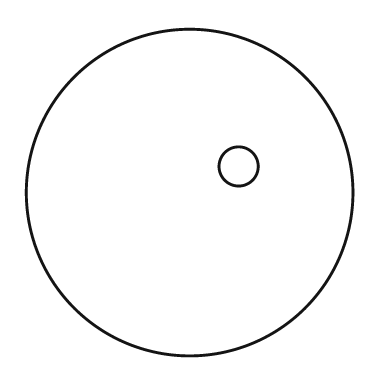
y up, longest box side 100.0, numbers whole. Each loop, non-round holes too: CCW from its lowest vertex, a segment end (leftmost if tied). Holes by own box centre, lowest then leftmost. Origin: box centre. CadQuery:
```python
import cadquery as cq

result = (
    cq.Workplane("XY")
    .moveTo(0.0, 0.0)
    .circle(50.0)
    .moveTo(15.0, 8.0)
    .circle(6.0)
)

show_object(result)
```